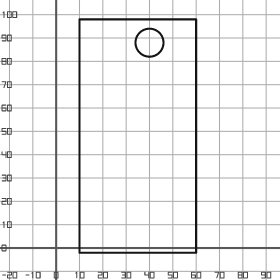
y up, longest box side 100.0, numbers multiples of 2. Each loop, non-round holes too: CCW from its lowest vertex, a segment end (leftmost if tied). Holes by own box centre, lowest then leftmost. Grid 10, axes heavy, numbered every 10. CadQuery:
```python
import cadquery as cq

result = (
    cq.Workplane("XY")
    .moveTo(10.0, -2.0)
    .lineTo(60.0, -2.0)
    .lineTo(60.0, 98.0)
    .lineTo(10.0, 98.0)
    .close()
    .moveTo(40.0, 88.0)
    .circle(6.0)
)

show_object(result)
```